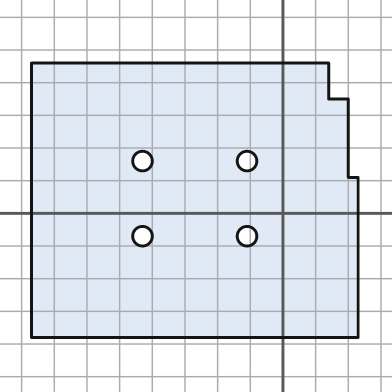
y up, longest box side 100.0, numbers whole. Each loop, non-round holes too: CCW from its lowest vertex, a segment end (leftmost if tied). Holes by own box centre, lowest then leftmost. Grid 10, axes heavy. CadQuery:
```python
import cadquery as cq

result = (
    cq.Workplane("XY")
    .moveTo(-77.0, -38.0)
    .lineTo(23.0, -38.0)
    .lineTo(23.0, 11.0)
    .lineTo(20.0, 11.0)
    .lineTo(20.0, 35.0)
    .lineTo(14.0, 35.0)
    .lineTo(14.0, 46.0)
    .lineTo(-77.0, 46.0)
    .close()
    .moveTo(-43.0, -7.0)
    .circle(3.0)
    .moveTo(-11.0, -7.0)
    .circle(3.0)
    .moveTo(-43.0, 16.0)
    .circle(3.0)
    .moveTo(-11.0, 16.0)
    .circle(3.0)
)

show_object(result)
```